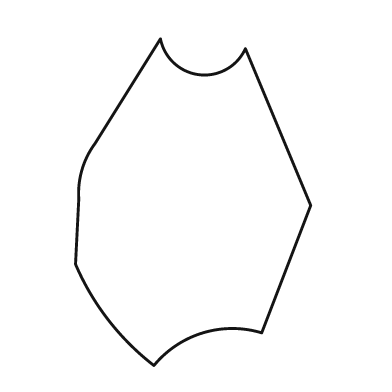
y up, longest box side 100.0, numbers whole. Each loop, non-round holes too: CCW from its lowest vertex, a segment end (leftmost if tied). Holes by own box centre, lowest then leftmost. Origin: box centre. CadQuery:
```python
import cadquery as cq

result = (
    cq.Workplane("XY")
    .moveTo(-12.0, -50.0)
    .threePointArc((3.0, -40.0), (21.0, -40.0))
    .lineTo(36.0, -1.0)
    .lineTo(16.0, 47.0)
    .threePointArc((2.0, 39.0), (-10.0, 50.0))
    .lineTo(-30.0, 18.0)
    .threePointArc((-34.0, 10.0), (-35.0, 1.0))
    .lineTo(-36.0, -19.0)
    .threePointArc((-26.0, -36.0), (-12.0, -50.0))
    .close()
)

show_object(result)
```